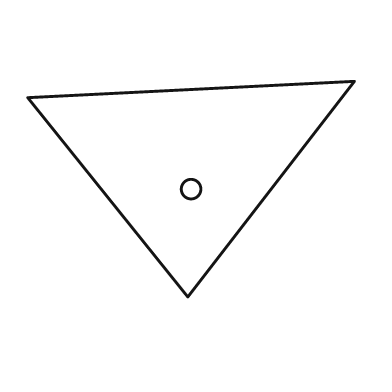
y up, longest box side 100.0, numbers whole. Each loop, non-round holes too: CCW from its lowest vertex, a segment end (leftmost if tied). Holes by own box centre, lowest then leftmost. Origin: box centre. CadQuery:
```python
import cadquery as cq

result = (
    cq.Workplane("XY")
    .moveTo(-1.0, -33.0)
    .lineTo(50.0, 33.0)
    .lineTo(-50.0, 28.0)
    .close()
    .moveTo(0.0, 0.0)
    .circle(3.0)
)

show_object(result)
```